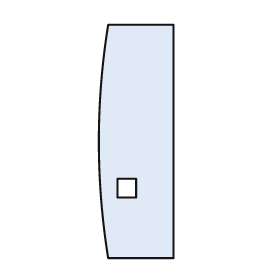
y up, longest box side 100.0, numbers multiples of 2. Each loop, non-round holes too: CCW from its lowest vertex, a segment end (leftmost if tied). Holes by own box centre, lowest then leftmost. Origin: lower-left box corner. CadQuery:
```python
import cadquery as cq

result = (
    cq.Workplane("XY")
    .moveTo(4.0, 0.0)
    .lineTo(32.0, 0.0)
    .lineTo(32.0, 100.0)
    .lineTo(4.0, 100.0)
    .threePointArc((0.0, 50.0), (4.0, 0.0))
    .close()
    .moveTo(8.0, 26.0)
    .lineTo(16.0, 26.0)
    .lineTo(16.0, 34.0)
    .lineTo(8.0, 34.0)
    .close()
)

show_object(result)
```